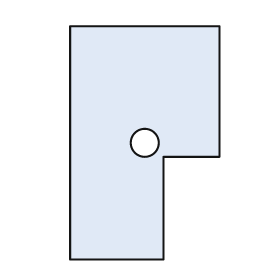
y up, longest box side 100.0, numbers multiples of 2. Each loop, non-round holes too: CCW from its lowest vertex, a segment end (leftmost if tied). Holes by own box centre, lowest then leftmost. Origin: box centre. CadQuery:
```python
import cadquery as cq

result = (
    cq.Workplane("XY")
    .moveTo(-32.0, -50.0)
    .lineTo(8.0, -50.0)
    .lineTo(8.0, -6.0)
    .lineTo(32.0, -6.0)
    .lineTo(32.0, 50.0)
    .lineTo(-32.0, 50.0)
    .close()
    .moveTo(0.0, 0.0)
    .circle(6.0)
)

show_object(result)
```